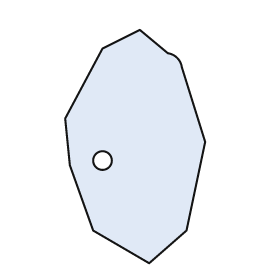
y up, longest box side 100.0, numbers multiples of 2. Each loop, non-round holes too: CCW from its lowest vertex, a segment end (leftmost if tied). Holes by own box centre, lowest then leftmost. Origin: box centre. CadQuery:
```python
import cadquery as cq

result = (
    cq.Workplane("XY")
    .moveTo(6.0, -50.0)
    .lineTo(22.0, -36.0)
    .lineTo(30.0, 2.0)
    .lineTo(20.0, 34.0)
    .threePointArc((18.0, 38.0), (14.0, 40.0))
    .lineTo(2.0, 50.0)
    .lineTo(-14.0, 42.0)
    .lineTo(-30.0, 12.0)
    .lineTo(-28.0, -8.0)
    .lineTo(-18.0, -36.0)
    .close()
    .moveTo(-14.0, -6.0)
    .circle(4.0)
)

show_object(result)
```